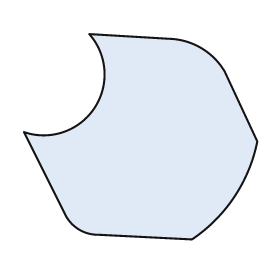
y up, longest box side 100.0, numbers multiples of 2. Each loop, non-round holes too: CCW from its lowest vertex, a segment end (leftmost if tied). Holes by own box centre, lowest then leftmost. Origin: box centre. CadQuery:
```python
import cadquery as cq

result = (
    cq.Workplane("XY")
    .moveTo(22.0, -44.0)
    .threePointArc((40.0, -26.0), (50.0, -2.0))
    .lineTo(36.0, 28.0)
    .threePointArc((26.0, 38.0), (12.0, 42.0))
    .lineTo(-22.0, 44.0)
    .threePointArc((-20.0, 12.0), (-50.0, 2.0))
    .lineTo(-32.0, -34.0)
    .threePointArc((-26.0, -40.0), (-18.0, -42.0))
    .close()
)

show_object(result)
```